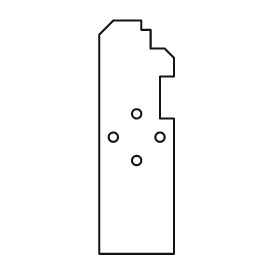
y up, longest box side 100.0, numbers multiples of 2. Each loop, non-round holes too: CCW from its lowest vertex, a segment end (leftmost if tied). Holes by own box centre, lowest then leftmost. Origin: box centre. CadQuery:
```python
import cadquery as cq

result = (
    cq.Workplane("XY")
    .moveTo(-16.0, -50.0)
    .lineTo(16.0, -50.0)
    .lineTo(16.0, 8.0)
    .lineTo(10.0, 8.0)
    .lineTo(10.0, 26.0)
    .lineTo(16.0, 26.0)
    .lineTo(16.0, 34.0)
    .lineTo(12.0, 38.0)
    .lineTo(6.0, 38.0)
    .lineTo(6.0, 46.0)
    .lineTo(2.0, 46.0)
    .lineTo(2.0, 50.0)
    .lineTo(-10.0, 50.0)
    .lineTo(-16.0, 44.0)
    .close()
    .moveTo(0.0, -10.0)
    .circle(2.0)
    .moveTo(-10.0, 0.0)
    .circle(2.0)
    .moveTo(10.0, 0.0)
    .circle(2.0)
    .moveTo(0.0, 10.0)
    .circle(2.0)
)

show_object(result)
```